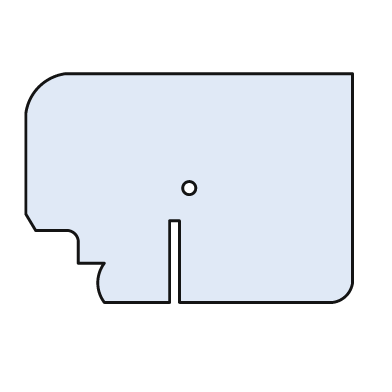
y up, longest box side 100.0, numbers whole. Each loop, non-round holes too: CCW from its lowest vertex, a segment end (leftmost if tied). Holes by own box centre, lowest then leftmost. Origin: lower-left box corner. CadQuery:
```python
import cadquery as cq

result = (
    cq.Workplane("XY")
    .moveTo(24.0, 0.0)
    .lineTo(44.0, 0.0)
    .lineTo(44.0, 25.0)
    .lineTo(47.0, 25.0)
    .lineTo(47.0, 0.0)
    .lineTo(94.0, 0.0)
    .threePointArc((98.0, 2.0), (100.0, 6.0))
    .lineTo(100.0, 70.0)
    .lineTo(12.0, 70.0)
    .threePointArc((4.0, 66.0), (0.0, 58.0))
    .lineTo(0.0, 27.0)
    .lineTo(3.0, 22.0)
    .lineTo(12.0, 22.0)
    .threePointArc((15.0, 21.0), (16.0, 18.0))
    .lineTo(16.0, 12.0)
    .lineTo(24.0, 12.0)
    .threePointArc((22.0, 6.0), (24.0, 0.0))
    .close()
    .moveTo(50.0, 35.0)
    .circle(2.0)
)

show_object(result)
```